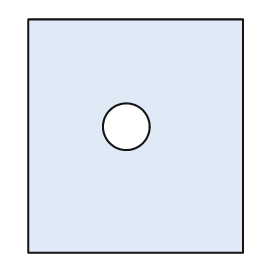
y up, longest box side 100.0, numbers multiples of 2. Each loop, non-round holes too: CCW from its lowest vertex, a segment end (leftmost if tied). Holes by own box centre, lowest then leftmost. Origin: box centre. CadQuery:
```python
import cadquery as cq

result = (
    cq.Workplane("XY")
    .moveTo(-46.0, -50.0)
    .lineTo(46.0, -50.0)
    .lineTo(46.0, 50.0)
    .lineTo(-46.0, 50.0)
    .close()
    .moveTo(-4.0, 4.0)
    .circle(10.0)
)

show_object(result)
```